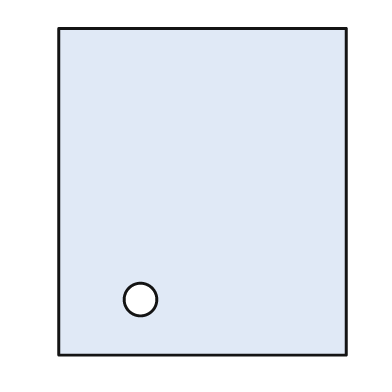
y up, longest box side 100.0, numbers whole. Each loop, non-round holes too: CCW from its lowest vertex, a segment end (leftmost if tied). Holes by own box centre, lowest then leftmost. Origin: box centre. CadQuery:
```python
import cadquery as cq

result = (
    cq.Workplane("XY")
    .moveTo(-44.0, -50.0)
    .lineTo(44.0, -50.0)
    .lineTo(44.0, 50.0)
    .lineTo(-44.0, 50.0)
    .close()
    .moveTo(-19.0, -33.0)
    .circle(5.0)
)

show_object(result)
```